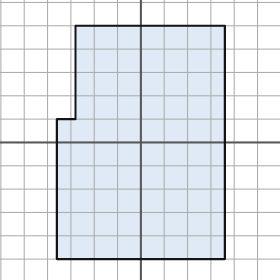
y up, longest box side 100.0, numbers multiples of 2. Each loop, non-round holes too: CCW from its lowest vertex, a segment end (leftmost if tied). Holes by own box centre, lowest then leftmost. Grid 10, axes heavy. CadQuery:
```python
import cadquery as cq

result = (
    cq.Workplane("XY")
    .moveTo(-36.0, -50.0)
    .lineTo(36.0, -50.0)
    .lineTo(36.0, 50.0)
    .lineTo(-28.0, 50.0)
    .lineTo(-28.0, 10.0)
    .lineTo(-36.0, 10.0)
    .close()
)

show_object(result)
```